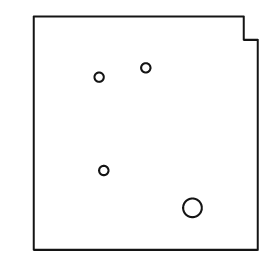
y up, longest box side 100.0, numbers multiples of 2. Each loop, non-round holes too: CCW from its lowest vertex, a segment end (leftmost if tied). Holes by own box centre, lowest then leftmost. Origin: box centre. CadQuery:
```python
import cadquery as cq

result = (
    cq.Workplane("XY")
    .moveTo(-48.0, -50.0)
    .lineTo(48.0, -50.0)
    .lineTo(48.0, 40.0)
    .lineTo(42.0, 40.0)
    .lineTo(42.0, 50.0)
    .lineTo(-48.0, 50.0)
    .close()
    .moveTo(20.0, -32.0)
    .circle(4.0)
    .moveTo(-18.0, -16.0)
    .circle(2.0)
    .moveTo(-20.0, 24.0)
    .circle(2.0)
    .moveTo(0.0, 28.0)
    .circle(2.0)
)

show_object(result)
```